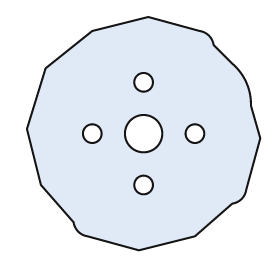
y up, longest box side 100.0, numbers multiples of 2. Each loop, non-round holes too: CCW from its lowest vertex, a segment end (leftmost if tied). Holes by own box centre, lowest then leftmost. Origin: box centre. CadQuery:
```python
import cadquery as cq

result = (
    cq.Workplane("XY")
    .moveTo(-2.0, -50.0)
    .lineTo(22.0, -44.0)
    .lineTo(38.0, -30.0)
    .threePointArc((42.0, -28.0), (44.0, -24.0))
    .lineTo(50.0, -2.0)
    .lineTo(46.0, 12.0)
    .threePointArc((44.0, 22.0), (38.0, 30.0))
    .lineTo(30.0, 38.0)
    .threePointArc((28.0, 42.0), (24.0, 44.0))
    .lineTo(2.0, 50.0)
    .lineTo(-22.0, 44.0)
    .lineTo(-42.0, 28.0)
    .lineTo(-50.0, 2.0)
    .lineTo(-44.0, -22.0)
    .lineTo(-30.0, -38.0)
    .threePointArc((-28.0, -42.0), (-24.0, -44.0))
    .close()
    .moveTo(0.0, -22.0)
    .circle(4.0)
    .moveTo(-22.0, 0.0)
    .circle(4.0)
    .moveTo(0.0, 0.0)
    .circle(8.0)
    .moveTo(22.0, 0.0)
    .circle(4.0)
    .moveTo(0.0, 22.0)
    .circle(4.0)
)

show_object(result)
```